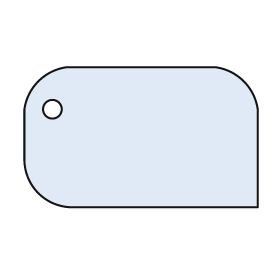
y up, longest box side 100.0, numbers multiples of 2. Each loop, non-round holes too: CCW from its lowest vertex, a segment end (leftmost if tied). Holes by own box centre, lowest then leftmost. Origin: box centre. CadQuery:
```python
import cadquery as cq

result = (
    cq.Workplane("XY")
    .moveTo(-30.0, -30.0)
    .lineTo(50.0, -30.0)
    .lineTo(50.0, 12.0)
    .threePointArc((44.0, 24.0), (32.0, 30.0))
    .lineTo(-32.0, 30.0)
    .threePointArc((-44.0, 24.0), (-50.0, 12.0))
    .lineTo(-50.0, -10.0)
    .threePointArc((-44.0, -24.0), (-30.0, -30.0))
    .close()
    .moveTo(-38.0, 12.0)
    .circle(4.0)
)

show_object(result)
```